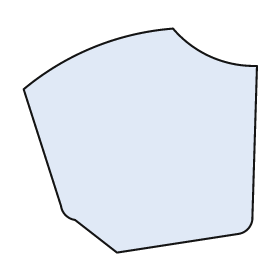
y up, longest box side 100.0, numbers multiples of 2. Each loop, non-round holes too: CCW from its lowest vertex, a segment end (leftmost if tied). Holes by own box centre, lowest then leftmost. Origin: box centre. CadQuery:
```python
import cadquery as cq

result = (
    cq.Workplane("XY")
    .moveTo(-10.0, -48.0)
    .lineTo(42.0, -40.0)
    .threePointArc((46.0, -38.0), (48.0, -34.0))
    .lineTo(50.0, 32.0)
    .threePointArc((30.0, 36.0), (14.0, 48.0))
    .threePointArc((-20.0, 40.0), (-50.0, 22.0))
    .lineTo(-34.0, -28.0)
    .threePointArc((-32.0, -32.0), (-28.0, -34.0))
    .close()
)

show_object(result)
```